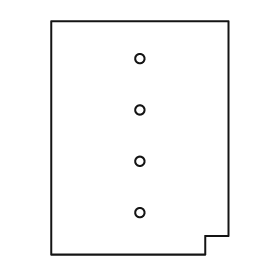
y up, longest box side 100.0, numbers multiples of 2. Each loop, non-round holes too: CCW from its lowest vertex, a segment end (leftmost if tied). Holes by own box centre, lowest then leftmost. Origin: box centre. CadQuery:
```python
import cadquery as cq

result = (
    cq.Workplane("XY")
    .moveTo(-38.0, -50.0)
    .lineTo(28.0, -50.0)
    .lineTo(28.0, -42.0)
    .lineTo(38.0, -42.0)
    .lineTo(38.0, 50.0)
    .lineTo(-38.0, 50.0)
    .close()
    .moveTo(0.0, -32.0)
    .circle(2.0)
    .moveTo(0.0, -10.0)
    .circle(2.0)
    .moveTo(0.0, 12.0)
    .circle(2.0)
    .moveTo(0.0, 34.0)
    .circle(2.0)
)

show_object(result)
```